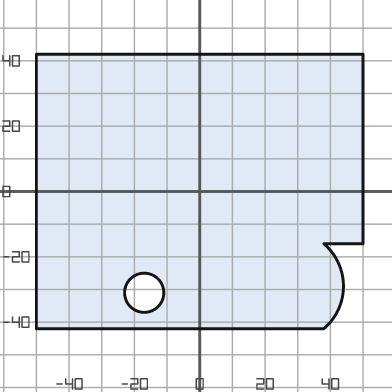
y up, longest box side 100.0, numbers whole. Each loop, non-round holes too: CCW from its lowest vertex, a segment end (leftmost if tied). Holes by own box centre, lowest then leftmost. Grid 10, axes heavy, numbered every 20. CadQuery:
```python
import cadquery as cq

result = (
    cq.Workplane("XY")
    .moveTo(-50.0, -42.0)
    .lineTo(38.0, -42.0)
    .threePointArc((44.0, -29.0), (38.0, -16.0))
    .lineTo(50.0, -16.0)
    .lineTo(50.0, 42.0)
    .lineTo(-50.0, 42.0)
    .close()
    .moveTo(-17.0, -31.0)
    .circle(6.0)
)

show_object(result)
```